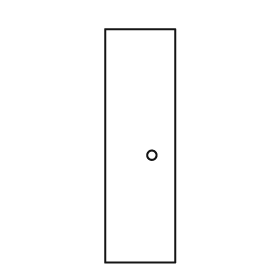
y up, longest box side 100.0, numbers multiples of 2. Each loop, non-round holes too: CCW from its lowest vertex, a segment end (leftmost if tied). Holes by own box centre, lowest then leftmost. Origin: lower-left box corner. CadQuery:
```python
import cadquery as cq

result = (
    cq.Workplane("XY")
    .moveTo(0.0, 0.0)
    .lineTo(30.0, 0.0)
    .lineTo(30.0, 100.0)
    .lineTo(0.0, 100.0)
    .close()
    .moveTo(20.0, 46.0)
    .circle(2.0)
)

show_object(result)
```